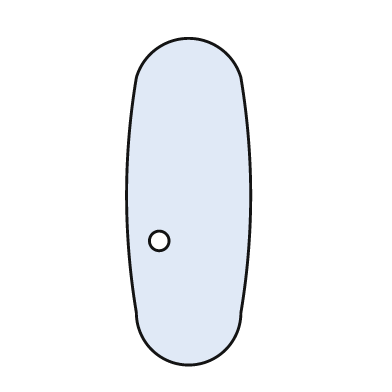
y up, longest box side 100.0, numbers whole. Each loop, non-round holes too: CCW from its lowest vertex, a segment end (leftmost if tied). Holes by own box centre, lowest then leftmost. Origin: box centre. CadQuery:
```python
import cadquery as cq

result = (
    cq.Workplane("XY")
    .moveTo(-16.0, -34.0)
    .threePointArc((0.0, -50.0), (16.0, -34.0))
    .threePointArc((19.0, 2.0), (16.0, 38.0))
    .threePointArc((0.0, 50.0), (-16.0, 38.0))
    .threePointArc((-19.0, 2.0), (-16.0, -34.0))
    .close()
    .moveTo(-9.0, -12.0)
    .circle(3.0)
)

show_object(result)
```